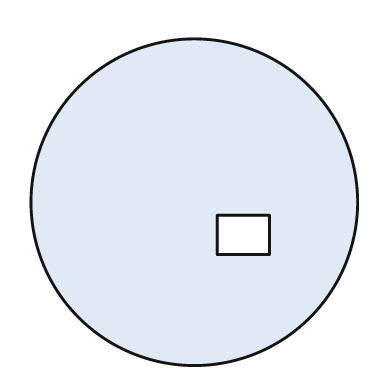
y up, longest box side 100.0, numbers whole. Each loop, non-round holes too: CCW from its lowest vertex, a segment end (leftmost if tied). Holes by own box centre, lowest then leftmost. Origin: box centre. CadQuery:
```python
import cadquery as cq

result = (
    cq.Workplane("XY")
    .moveTo(0.0, 0.0)
    .circle(50.0)
    .moveTo(7.0, -16.0)
    .lineTo(23.0, -16.0)
    .lineTo(23.0, -4.0)
    .lineTo(7.0, -4.0)
    .close()
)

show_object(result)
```